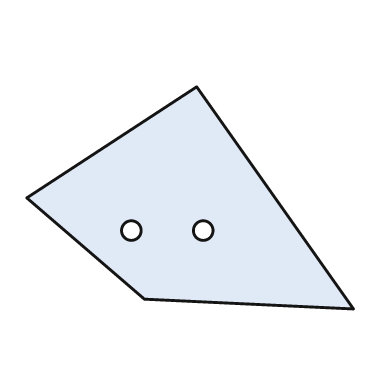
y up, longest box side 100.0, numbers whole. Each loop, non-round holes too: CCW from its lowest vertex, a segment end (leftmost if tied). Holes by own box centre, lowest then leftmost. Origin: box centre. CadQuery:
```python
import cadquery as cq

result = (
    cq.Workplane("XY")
    .moveTo(50.0, -34.0)
    .lineTo(2.0, 34.0)
    .lineTo(-50.0, 0.0)
    .lineTo(-14.0, -31.0)
    .close()
    .moveTo(-18.0, -10.0)
    .circle(3.0)
    .moveTo(4.0, -10.0)
    .circle(3.0)
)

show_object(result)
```